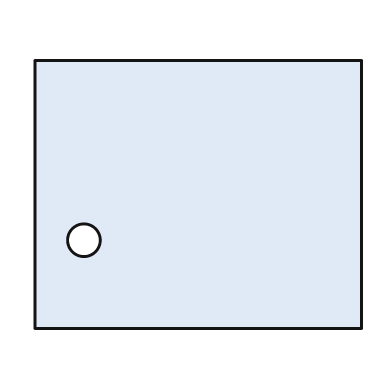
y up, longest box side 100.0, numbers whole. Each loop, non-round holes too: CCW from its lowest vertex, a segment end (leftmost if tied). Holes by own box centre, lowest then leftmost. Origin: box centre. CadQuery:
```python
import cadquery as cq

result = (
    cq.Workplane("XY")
    .moveTo(-50.0, -41.0)
    .lineTo(50.0, -41.0)
    .lineTo(50.0, 41.0)
    .lineTo(-50.0, 41.0)
    .close()
    .moveTo(-35.0, -14.0)
    .circle(5.0)
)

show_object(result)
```